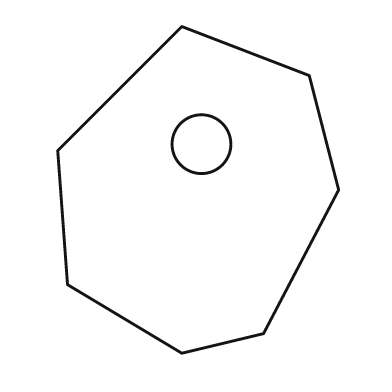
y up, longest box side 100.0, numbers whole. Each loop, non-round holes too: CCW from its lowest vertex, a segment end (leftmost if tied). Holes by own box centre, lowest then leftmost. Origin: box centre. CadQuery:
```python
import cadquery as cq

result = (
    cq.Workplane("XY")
    .moveTo(-5.0, -50.0)
    .lineTo(20.0, -44.0)
    .lineTo(43.0, 0.0)
    .lineTo(34.0, 35.0)
    .lineTo(-5.0, 50.0)
    .lineTo(-43.0, 12.0)
    .lineTo(-40.0, -29.0)
    .close()
    .moveTo(1.0, 14.0)
    .circle(9.0)
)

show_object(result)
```